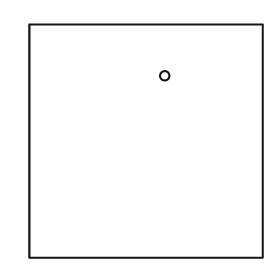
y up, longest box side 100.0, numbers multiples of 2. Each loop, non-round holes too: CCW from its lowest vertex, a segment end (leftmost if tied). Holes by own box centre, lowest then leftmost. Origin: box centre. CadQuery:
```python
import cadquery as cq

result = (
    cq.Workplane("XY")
    .moveTo(-50.0, -50.0)
    .lineTo(50.0, -50.0)
    .lineTo(50.0, 50.0)
    .lineTo(-50.0, 50.0)
    .close()
    .moveTo(8.0, 28.0)
    .circle(2.0)
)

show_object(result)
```